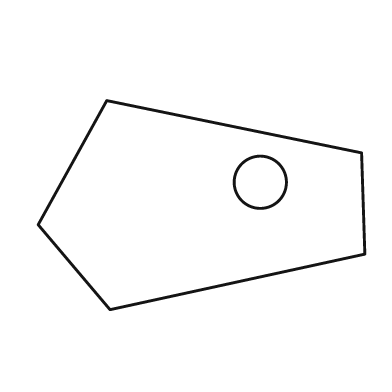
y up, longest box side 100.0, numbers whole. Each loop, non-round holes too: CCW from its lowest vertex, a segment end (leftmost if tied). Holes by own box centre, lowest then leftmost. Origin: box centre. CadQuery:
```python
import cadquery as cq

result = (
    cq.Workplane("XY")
    .moveTo(-28.0, -32.0)
    .lineTo(50.0, -15.0)
    .lineTo(49.0, 16.0)
    .lineTo(-29.0, 32.0)
    .lineTo(-50.0, -6.0)
    .close()
    .moveTo(18.0, 7.0)
    .circle(8.0)
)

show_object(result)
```